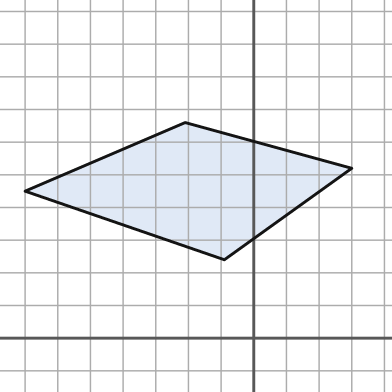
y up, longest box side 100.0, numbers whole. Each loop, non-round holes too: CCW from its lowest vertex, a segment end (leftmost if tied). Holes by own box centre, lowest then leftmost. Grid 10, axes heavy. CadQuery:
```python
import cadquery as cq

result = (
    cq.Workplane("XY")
    .moveTo(-9.0, 24.0)
    .lineTo(30.0, 52.0)
    .lineTo(-21.0, 66.0)
    .lineTo(-70.0, 45.0)
    .close()
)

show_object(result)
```